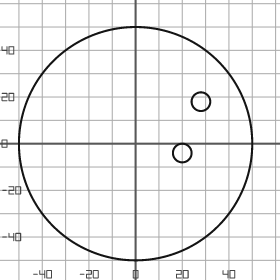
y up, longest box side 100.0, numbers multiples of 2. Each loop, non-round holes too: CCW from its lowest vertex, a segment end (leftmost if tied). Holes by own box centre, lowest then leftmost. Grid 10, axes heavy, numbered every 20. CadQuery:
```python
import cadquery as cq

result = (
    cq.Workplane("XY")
    .moveTo(0.0, 0.0)
    .circle(50.0)
    .moveTo(20.0, -4.0)
    .circle(4.0)
    .moveTo(28.0, 18.0)
    .circle(4.0)
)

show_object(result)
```